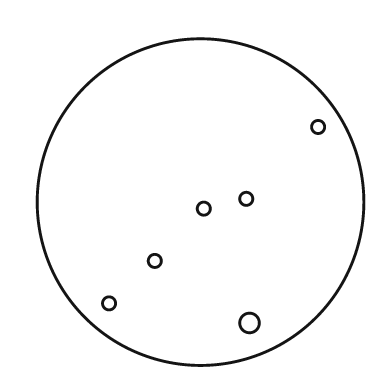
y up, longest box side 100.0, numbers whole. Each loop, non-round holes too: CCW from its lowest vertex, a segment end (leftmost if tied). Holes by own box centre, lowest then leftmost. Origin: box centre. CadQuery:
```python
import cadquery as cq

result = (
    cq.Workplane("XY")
    .moveTo(0.0, 0.0)
    .circle(50.0)
    .moveTo(15.0, -37.0)
    .circle(3.0)
    .moveTo(-28.0, -31.0)
    .circle(2.0)
    .moveTo(-14.0, -18.0)
    .circle(2.0)
    .moveTo(1.0, -2.0)
    .circle(2.0)
    .moveTo(14.0, 1.0)
    .circle(2.0)
    .moveTo(36.0, 23.0)
    .circle(2.0)
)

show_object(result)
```